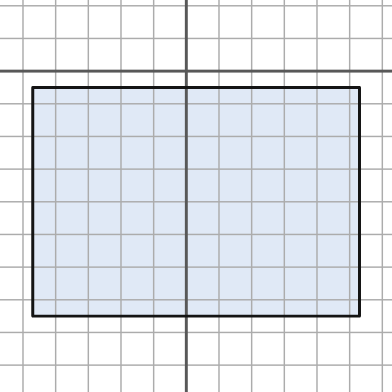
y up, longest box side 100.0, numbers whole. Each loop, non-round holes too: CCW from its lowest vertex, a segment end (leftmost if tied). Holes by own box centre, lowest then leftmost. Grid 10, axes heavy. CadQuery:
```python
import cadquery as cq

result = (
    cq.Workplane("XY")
    .moveTo(-47.0, -75.0)
    .lineTo(53.0, -75.0)
    .lineTo(53.0, -5.0)
    .lineTo(-47.0, -5.0)
    .close()
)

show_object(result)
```